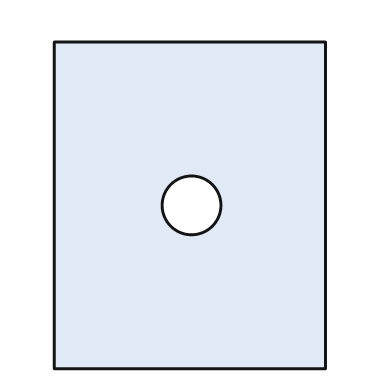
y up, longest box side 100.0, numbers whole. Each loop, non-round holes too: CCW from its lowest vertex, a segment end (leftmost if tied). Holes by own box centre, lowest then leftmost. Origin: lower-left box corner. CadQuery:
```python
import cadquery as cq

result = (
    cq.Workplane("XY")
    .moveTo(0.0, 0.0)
    .lineTo(83.0, 0.0)
    .lineTo(83.0, 100.0)
    .lineTo(0.0, 100.0)
    .close()
    .moveTo(42.0, 50.0)
    .circle(9.0)
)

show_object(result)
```